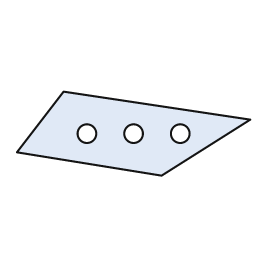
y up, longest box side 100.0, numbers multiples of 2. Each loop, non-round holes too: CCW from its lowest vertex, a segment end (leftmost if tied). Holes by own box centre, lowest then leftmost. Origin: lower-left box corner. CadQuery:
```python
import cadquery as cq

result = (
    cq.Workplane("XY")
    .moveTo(62.0, 0.0)
    .lineTo(100.0, 24.0)
    .lineTo(20.0, 36.0)
    .lineTo(0.0, 10.0)
    .close()
    .moveTo(30.0, 18.0)
    .circle(4.0)
    .moveTo(50.0, 18.0)
    .circle(4.0)
    .moveTo(70.0, 18.0)
    .circle(4.0)
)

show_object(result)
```